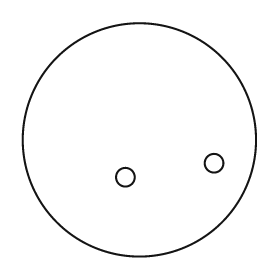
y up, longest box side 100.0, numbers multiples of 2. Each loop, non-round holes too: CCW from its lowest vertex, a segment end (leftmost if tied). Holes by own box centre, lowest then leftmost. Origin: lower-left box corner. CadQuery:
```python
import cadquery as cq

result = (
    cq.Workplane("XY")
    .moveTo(50.0, 50.0)
    .circle(50.0)
    .moveTo(44.0, 34.0)
    .circle(4.0)
    .moveTo(82.0, 40.0)
    .circle(4.0)
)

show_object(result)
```